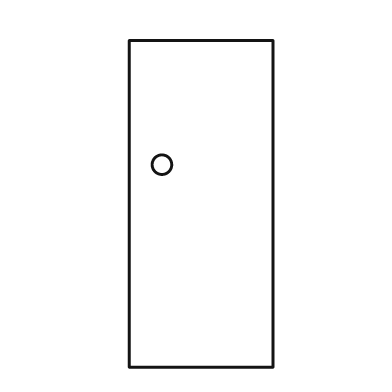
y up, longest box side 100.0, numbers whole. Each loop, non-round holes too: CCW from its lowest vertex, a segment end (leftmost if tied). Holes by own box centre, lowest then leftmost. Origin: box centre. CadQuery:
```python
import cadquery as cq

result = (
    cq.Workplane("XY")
    .moveTo(-22.0, -50.0)
    .lineTo(22.0, -50.0)
    .lineTo(22.0, 50.0)
    .lineTo(-22.0, 50.0)
    .close()
    .moveTo(-12.0, 12.0)
    .circle(3.0)
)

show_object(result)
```